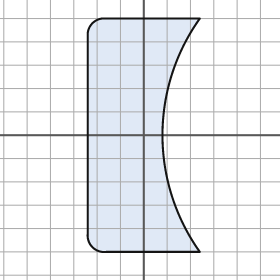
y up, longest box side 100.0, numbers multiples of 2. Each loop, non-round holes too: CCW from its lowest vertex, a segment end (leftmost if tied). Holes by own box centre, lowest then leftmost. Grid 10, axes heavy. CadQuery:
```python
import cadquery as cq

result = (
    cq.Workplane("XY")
    .moveTo(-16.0, -50.0)
    .lineTo(24.0, -50.0)
    .threePointArc((8.0, 0.0), (24.0, 50.0))
    .lineTo(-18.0, 50.0)
    .threePointArc((-22.0, 48.0), (-24.0, 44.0))
    .lineTo(-24.0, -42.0)
    .threePointArc((-22.0, -48.0), (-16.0, -50.0))
    .close()
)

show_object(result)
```